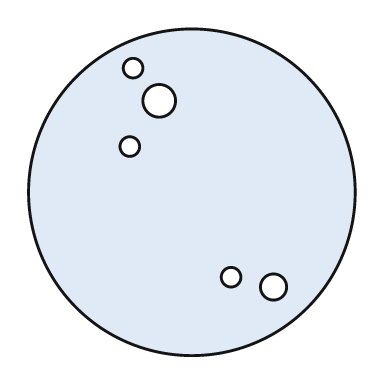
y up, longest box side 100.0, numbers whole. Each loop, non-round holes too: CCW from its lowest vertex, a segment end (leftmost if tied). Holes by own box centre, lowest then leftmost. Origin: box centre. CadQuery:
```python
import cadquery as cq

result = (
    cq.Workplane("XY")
    .moveTo(0.0, 0.0)
    .circle(50.0)
    .moveTo(25.0, -29.0)
    .circle(4.0)
    .moveTo(12.0, -26.0)
    .circle(3.0)
    .moveTo(-19.0, 14.0)
    .circle(3.0)
    .moveTo(-10.0, 28.0)
    .circle(5.0)
    .moveTo(-18.0, 38.0)
    .circle(3.0)
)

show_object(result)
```